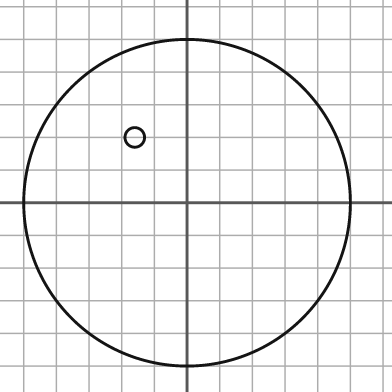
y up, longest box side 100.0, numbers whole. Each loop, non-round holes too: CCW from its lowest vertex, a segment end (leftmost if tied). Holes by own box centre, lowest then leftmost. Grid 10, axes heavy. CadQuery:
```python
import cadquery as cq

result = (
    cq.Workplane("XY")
    .moveTo(0.0, 0.0)
    .circle(50.0)
    .moveTo(-16.0, 20.0)
    .circle(3.0)
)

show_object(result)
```